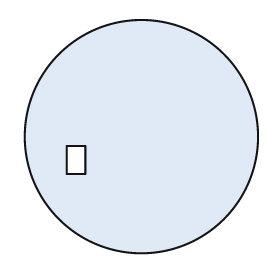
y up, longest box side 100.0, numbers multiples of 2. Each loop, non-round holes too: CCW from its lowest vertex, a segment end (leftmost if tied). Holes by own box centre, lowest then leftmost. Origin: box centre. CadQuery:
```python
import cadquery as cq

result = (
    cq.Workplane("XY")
    .moveTo(0.0, 0.0)
    .circle(50.0)
    .moveTo(-32.0, -16.0)
    .lineTo(-24.0, -16.0)
    .lineTo(-24.0, -4.0)
    .lineTo(-32.0, -4.0)
    .close()
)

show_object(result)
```